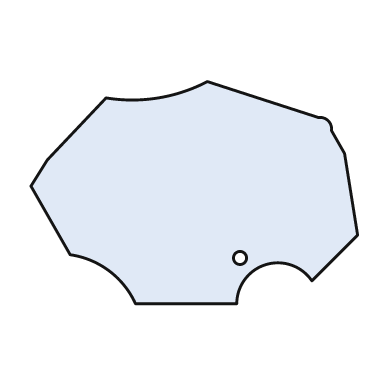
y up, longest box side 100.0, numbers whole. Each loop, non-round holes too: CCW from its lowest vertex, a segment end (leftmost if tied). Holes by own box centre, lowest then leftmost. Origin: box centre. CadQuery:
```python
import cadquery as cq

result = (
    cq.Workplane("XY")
    .moveTo(-18.0, -34.0)
    .lineTo(13.0, -34.0)
    .threePointArc((22.0, -22.0), (36.0, -27.0))
    .lineTo(50.0, -13.0)
    .lineTo(46.0, 12.0)
    .lineTo(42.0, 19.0)
    .threePointArc((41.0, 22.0), (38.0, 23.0))
    .lineTo(4.0, 34.0)
    .threePointArc((-11.0, 29.0), (-27.0, 29.0))
    .lineTo(-45.0, 10.0)
    .lineTo(-50.0, 2.0)
    .lineTo(-38.0, -19.0)
    .threePointArc((-26.0, -24.0), (-18.0, -34.0))
    .close()
    .moveTo(14.0, -20.0)
    .circle(2.0)
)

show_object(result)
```